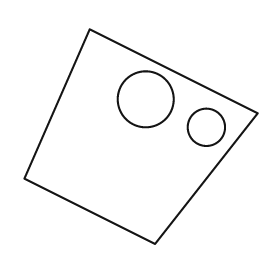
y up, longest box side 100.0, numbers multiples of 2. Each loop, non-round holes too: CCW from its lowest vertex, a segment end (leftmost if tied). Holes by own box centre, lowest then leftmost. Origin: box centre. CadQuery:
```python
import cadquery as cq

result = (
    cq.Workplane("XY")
    .moveTo(6.0, -46.0)
    .lineTo(50.0, 10.0)
    .lineTo(-22.0, 46.0)
    .lineTo(-50.0, -18.0)
    .close()
    .moveTo(28.0, 4.0)
    .circle(8.0)
    .moveTo(2.0, 16.0)
    .circle(12.0)
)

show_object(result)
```